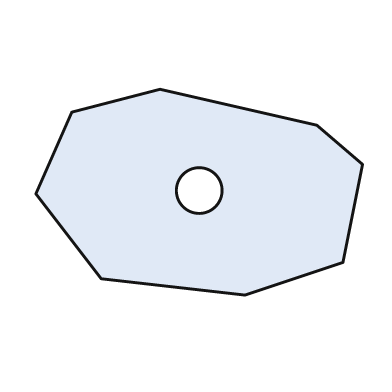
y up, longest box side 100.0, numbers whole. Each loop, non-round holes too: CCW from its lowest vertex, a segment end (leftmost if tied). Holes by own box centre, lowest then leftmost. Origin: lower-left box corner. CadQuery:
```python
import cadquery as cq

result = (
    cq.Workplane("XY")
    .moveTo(64.0, 0.0)
    .lineTo(94.0, 10.0)
    .lineTo(100.0, 40.0)
    .lineTo(86.0, 52.0)
    .lineTo(38.0, 63.0)
    .lineTo(11.0, 56.0)
    .lineTo(0.0, 31.0)
    .lineTo(20.0, 5.0)
    .close()
    .moveTo(50.0, 32.0)
    .circle(7.0)
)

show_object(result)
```